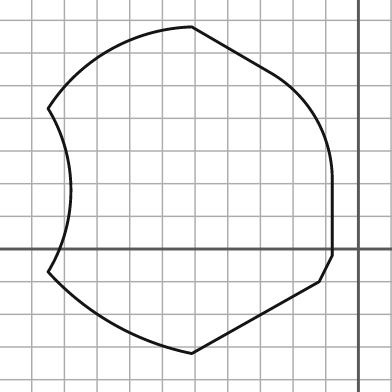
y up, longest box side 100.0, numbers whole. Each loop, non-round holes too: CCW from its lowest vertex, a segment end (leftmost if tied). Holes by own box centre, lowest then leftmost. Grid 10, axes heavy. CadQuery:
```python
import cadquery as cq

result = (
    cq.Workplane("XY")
    .moveTo(-51.0, -32.0)
    .lineTo(-12.0, -10.0)
    .lineTo(-8.0, -2.0)
    .lineTo(-8.0, 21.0)
    .threePointArc((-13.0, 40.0), (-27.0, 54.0))
    .lineTo(-51.0, 68.0)
    .threePointArc((-76.0, 61.0), (-95.0, 43.0))
    .threePointArc((-88.0, 18.0), (-95.0, -7.0))
    .threePointArc((-75.0, -23.0), (-51.0, -32.0))
    .close()
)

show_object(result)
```